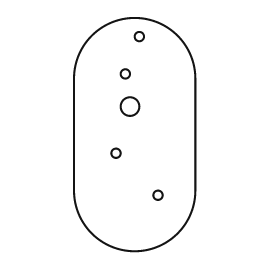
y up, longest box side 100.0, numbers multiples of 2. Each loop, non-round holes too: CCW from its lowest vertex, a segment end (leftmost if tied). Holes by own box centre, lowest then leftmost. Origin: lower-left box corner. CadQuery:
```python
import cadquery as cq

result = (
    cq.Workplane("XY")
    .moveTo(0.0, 26.0)
    .threePointArc((26.0, 0.0), (52.0, 26.0))
    .lineTo(52.0, 74.0)
    .threePointArc((26.0, 100.0), (0.0, 74.0))
    .close()
    .moveTo(36.0, 24.0)
    .circle(2.0)
    .moveTo(18.0, 42.0)
    .circle(2.0)
    .moveTo(24.0, 62.0)
    .circle(4.0)
    .moveTo(22.0, 76.0)
    .circle(2.0)
    .moveTo(28.0, 92.0)
    .circle(2.0)
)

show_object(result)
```